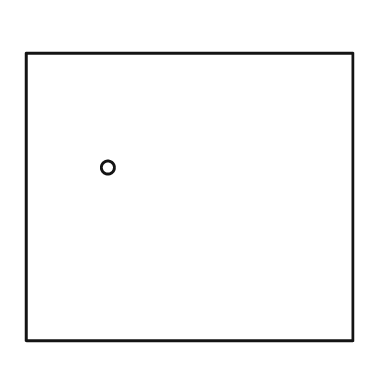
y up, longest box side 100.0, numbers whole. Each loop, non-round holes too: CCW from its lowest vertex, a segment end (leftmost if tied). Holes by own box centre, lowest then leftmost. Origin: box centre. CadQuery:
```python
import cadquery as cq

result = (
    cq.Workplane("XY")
    .moveTo(-50.0, -44.0)
    .lineTo(50.0, -44.0)
    .lineTo(50.0, 44.0)
    .lineTo(-50.0, 44.0)
    .close()
    .moveTo(-25.0, 9.0)
    .circle(2.0)
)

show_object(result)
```